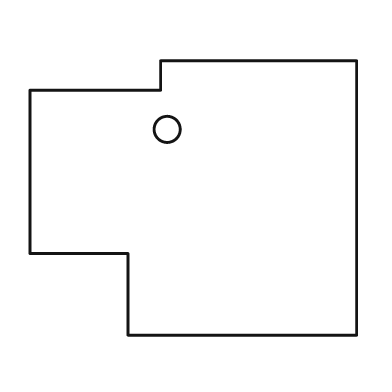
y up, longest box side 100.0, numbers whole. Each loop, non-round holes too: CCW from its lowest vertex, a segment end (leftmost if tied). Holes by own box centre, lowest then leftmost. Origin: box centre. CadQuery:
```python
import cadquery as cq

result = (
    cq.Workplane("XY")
    .moveTo(-20.0, -42.0)
    .lineTo(50.0, -42.0)
    .lineTo(50.0, 42.0)
    .lineTo(-10.0, 42.0)
    .lineTo(-10.0, 33.0)
    .lineTo(-50.0, 33.0)
    .lineTo(-50.0, -17.0)
    .lineTo(-20.0, -17.0)
    .close()
    .moveTo(-8.0, 21.0)
    .circle(4.0)
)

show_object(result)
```